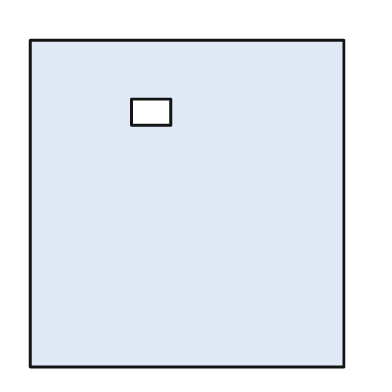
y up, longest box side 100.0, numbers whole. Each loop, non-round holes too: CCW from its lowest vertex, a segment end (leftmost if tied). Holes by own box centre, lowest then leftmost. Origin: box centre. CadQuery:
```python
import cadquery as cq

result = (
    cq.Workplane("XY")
    .moveTo(-48.0, -50.0)
    .lineTo(48.0, -50.0)
    .lineTo(48.0, 50.0)
    .lineTo(-48.0, 50.0)
    .close()
    .moveTo(-17.0, 24.0)
    .lineTo(-5.0, 24.0)
    .lineTo(-5.0, 32.0)
    .lineTo(-17.0, 32.0)
    .close()
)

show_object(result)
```